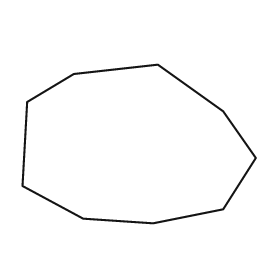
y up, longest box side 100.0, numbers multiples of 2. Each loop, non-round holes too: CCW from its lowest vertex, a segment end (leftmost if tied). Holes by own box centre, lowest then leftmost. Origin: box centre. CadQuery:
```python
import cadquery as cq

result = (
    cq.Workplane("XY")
    .moveTo(6.0, -34.0)
    .lineTo(36.0, -28.0)
    .lineTo(50.0, -6.0)
    .lineTo(36.0, 14.0)
    .lineTo(8.0, 34.0)
    .lineTo(-28.0, 30.0)
    .lineTo(-48.0, 18.0)
    .lineTo(-50.0, -18.0)
    .lineTo(-24.0, -32.0)
    .close()
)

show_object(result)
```